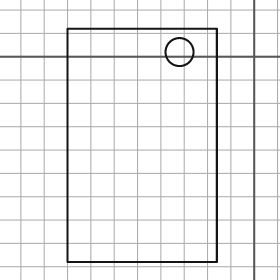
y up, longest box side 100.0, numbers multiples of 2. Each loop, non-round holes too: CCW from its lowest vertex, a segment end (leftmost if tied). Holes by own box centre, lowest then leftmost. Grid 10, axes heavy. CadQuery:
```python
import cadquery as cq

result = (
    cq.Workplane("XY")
    .moveTo(-80.0, -88.0)
    .lineTo(-16.0, -88.0)
    .lineTo(-16.0, 12.0)
    .lineTo(-80.0, 12.0)
    .close()
    .moveTo(-32.0, 2.0)
    .circle(6.0)
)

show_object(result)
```